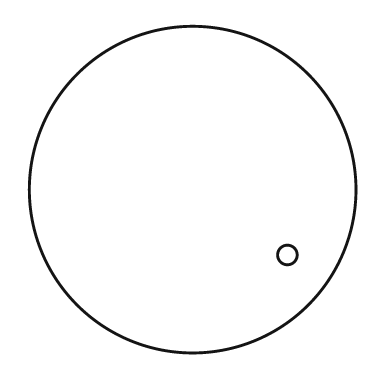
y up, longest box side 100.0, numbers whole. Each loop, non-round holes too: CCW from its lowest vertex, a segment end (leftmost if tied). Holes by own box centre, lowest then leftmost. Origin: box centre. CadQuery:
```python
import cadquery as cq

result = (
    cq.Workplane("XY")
    .moveTo(0.0, 0.0)
    .circle(50.0)
    .moveTo(29.0, -20.0)
    .circle(3.0)
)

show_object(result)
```